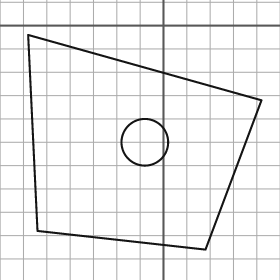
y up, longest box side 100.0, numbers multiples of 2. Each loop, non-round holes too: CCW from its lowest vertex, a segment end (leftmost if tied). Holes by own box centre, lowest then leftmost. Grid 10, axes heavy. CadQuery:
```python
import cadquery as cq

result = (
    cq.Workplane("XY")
    .moveTo(18.0, -96.0)
    .lineTo(42.0, -32.0)
    .lineTo(-58.0, -4.0)
    .lineTo(-54.0, -88.0)
    .close()
    .moveTo(-8.0, -50.0)
    .circle(10.0)
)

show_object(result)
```